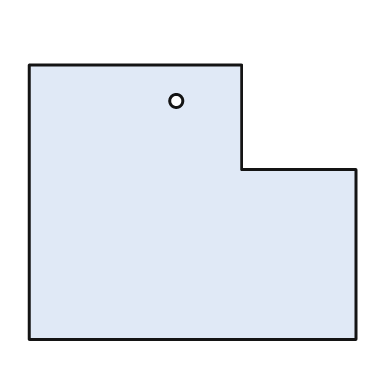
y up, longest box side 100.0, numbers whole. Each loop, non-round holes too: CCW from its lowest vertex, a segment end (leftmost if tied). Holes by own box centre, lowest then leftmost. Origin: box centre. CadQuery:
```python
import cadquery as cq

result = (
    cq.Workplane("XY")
    .moveTo(-50.0, -42.0)
    .lineTo(50.0, -42.0)
    .lineTo(50.0, 10.0)
    .lineTo(15.0, 10.0)
    .lineTo(15.0, 42.0)
    .lineTo(-50.0, 42.0)
    .close()
    .moveTo(-5.0, 31.0)
    .circle(2.0)
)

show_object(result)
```